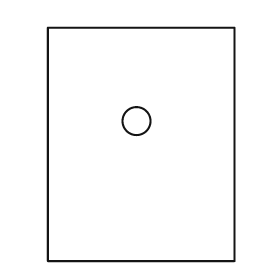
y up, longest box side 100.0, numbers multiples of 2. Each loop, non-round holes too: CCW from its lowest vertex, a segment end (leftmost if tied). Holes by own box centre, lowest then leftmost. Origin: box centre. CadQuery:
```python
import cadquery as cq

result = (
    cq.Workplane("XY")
    .moveTo(-40.0, -50.0)
    .lineTo(40.0, -50.0)
    .lineTo(40.0, 50.0)
    .lineTo(-40.0, 50.0)
    .close()
    .moveTo(-2.0, 10.0)
    .circle(6.0)
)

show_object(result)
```